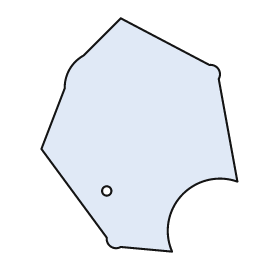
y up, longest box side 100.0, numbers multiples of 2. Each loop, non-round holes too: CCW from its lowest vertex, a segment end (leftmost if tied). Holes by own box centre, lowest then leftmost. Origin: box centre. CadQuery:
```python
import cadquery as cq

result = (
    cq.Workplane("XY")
    .moveTo(14.0, -50.0)
    .threePointArc((18.0, -26.0), (42.0, -20.0))
    .lineTo(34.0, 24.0)
    .threePointArc((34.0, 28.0), (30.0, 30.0))
    .lineTo(-8.0, 50.0)
    .lineTo(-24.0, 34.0)
    .threePointArc((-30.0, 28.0), (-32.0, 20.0))
    .lineTo(-42.0, -6.0)
    .lineTo(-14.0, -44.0)
    .threePointArc((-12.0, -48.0), (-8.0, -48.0))
    .close()
    .moveTo(-14.0, -24.0)
    .circle(2.0)
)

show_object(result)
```